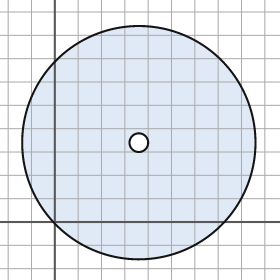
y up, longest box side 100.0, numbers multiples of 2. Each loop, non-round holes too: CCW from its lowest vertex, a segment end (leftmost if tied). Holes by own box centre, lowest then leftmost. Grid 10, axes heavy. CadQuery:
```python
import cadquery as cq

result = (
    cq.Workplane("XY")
    .moveTo(36.0, 34.0)
    .circle(50.0)
    .moveTo(36.0, 34.0)
    .circle(4.0)
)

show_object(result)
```